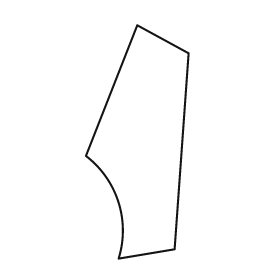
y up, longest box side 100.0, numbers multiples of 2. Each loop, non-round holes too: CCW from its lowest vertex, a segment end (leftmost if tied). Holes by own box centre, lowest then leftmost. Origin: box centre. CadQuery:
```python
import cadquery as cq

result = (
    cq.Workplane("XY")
    .moveTo(-8.0, -50.0)
    .lineTo(16.0, -46.0)
    .lineTo(22.0, 38.0)
    .lineTo(0.0, 50.0)
    .lineTo(-22.0, -6.0)
    .threePointArc((-8.0, -26.0), (-8.0, -50.0))
    .close()
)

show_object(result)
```